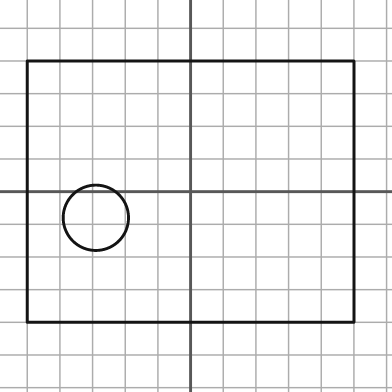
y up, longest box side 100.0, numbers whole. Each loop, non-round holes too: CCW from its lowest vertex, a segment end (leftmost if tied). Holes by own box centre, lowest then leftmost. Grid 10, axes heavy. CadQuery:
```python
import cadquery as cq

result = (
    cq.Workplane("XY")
    .moveTo(-50.0, -40.0)
    .lineTo(50.0, -40.0)
    .lineTo(50.0, 40.0)
    .lineTo(-50.0, 40.0)
    .close()
    .moveTo(-29.0, -8.0)
    .circle(10.0)
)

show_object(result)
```